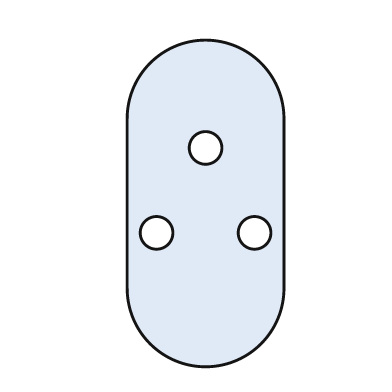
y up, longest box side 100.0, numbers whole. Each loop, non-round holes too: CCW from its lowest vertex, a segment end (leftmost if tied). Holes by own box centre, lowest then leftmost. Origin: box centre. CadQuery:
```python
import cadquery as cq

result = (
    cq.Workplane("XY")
    .moveTo(-24.0, -26.0)
    .threePointArc((0.0, -50.0), (24.0, -26.0))
    .lineTo(24.0, 26.0)
    .threePointArc((0.0, 50.0), (-24.0, 26.0))
    .close()
    .moveTo(-15.0, -9.0)
    .circle(5.0)
    .moveTo(15.0, -9.0)
    .circle(5.0)
    .moveTo(0.0, 17.0)
    .circle(5.0)
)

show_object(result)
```